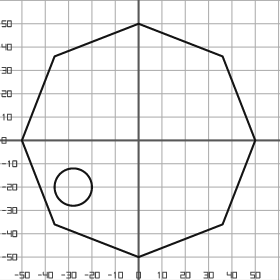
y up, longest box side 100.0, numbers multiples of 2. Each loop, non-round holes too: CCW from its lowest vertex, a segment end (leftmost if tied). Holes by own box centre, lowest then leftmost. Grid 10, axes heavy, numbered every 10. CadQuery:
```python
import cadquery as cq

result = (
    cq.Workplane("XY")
    .moveTo(0.0, -50.0)
    .lineTo(36.0, -36.0)
    .lineTo(50.0, 0.0)
    .lineTo(36.0, 36.0)
    .lineTo(0.0, 50.0)
    .lineTo(-36.0, 36.0)
    .lineTo(-50.0, 0.0)
    .lineTo(-36.0, -36.0)
    .close()
    .moveTo(-28.0, -20.0)
    .circle(8.0)
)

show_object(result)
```